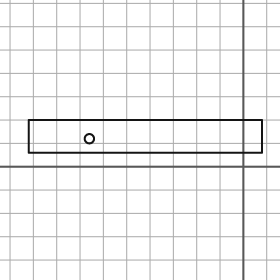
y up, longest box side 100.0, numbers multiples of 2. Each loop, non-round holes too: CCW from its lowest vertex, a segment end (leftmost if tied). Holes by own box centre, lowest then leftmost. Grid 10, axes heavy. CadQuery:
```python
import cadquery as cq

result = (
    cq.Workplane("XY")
    .moveTo(-92.0, 6.0)
    .lineTo(8.0, 6.0)
    .lineTo(8.0, 20.0)
    .lineTo(-92.0, 20.0)
    .close()
    .moveTo(-66.0, 12.0)
    .circle(2.0)
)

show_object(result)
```